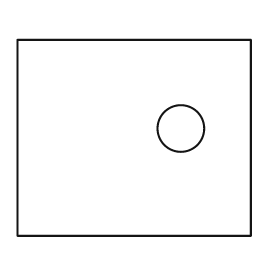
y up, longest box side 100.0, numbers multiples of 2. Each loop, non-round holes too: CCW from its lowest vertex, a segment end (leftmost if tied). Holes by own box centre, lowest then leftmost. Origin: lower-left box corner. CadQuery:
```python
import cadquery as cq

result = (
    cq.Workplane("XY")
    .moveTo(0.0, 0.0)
    .lineTo(100.0, 0.0)
    .lineTo(100.0, 84.0)
    .lineTo(0.0, 84.0)
    .close()
    .moveTo(70.0, 46.0)
    .circle(10.0)
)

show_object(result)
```